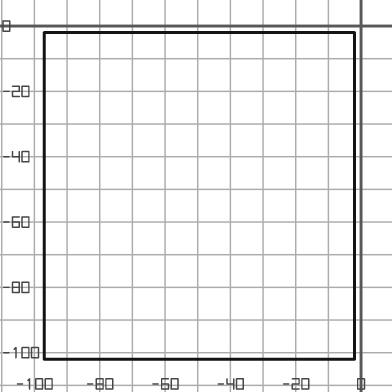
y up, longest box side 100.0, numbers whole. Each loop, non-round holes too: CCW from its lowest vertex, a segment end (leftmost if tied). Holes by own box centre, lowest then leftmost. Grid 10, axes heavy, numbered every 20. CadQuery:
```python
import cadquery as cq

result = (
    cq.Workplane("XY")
    .moveTo(-97.0, -102.0)
    .lineTo(-2.0, -102.0)
    .lineTo(-2.0, -2.0)
    .lineTo(-97.0, -2.0)
    .close()
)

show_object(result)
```